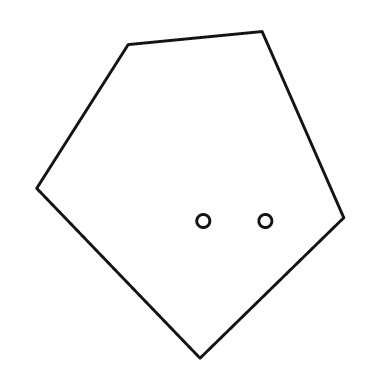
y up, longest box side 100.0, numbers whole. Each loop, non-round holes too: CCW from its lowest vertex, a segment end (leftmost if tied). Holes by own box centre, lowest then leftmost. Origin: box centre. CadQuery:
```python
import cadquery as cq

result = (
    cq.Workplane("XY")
    .moveTo(3.0, -50.0)
    .lineTo(47.0, -7.0)
    .lineTo(22.0, 50.0)
    .lineTo(-19.0, 46.0)
    .lineTo(-47.0, 2.0)
    .close()
    .moveTo(4.0, -8.0)
    .circle(2.0)
    .moveTo(23.0, -8.0)
    .circle(2.0)
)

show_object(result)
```